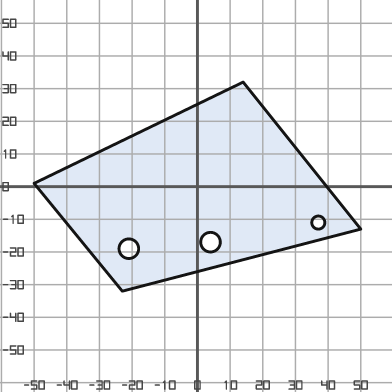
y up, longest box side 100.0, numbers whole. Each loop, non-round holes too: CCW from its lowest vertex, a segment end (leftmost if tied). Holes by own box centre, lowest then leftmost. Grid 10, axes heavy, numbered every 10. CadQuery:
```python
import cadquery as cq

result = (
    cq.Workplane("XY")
    .moveTo(-23.0, -32.0)
    .lineTo(50.0, -13.0)
    .lineTo(14.0, 32.0)
    .lineTo(-50.0, 1.0)
    .close()
    .moveTo(-21.0, -19.0)
    .circle(3.0)
    .moveTo(4.0, -17.0)
    .circle(3.0)
    .moveTo(37.0, -11.0)
    .circle(2.0)
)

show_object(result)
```